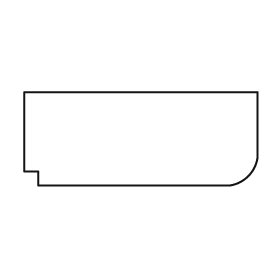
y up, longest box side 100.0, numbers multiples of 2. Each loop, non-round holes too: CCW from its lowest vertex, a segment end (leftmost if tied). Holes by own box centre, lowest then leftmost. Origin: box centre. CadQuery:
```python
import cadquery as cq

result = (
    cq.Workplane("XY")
    .moveTo(-44.0, -20.0)
    .lineTo(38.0, -20.0)
    .threePointArc((46.0, -16.0), (50.0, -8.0))
    .lineTo(50.0, 20.0)
    .lineTo(-50.0, 20.0)
    .lineTo(-50.0, -14.0)
    .lineTo(-44.0, -14.0)
    .close()
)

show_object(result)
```